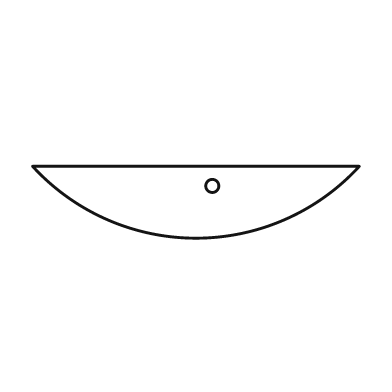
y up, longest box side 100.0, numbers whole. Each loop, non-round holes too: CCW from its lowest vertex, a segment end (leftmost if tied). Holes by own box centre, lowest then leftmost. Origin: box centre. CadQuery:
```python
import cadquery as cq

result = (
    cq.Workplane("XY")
    .moveTo(-50.0, 11.0)
    .threePointArc((0.0, -11.0), (50.0, 11.0))
    .close()
    .moveTo(5.0, 5.0)
    .circle(2.0)
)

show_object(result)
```